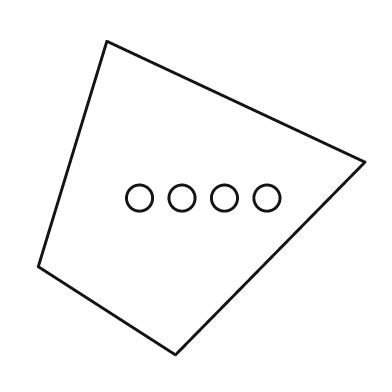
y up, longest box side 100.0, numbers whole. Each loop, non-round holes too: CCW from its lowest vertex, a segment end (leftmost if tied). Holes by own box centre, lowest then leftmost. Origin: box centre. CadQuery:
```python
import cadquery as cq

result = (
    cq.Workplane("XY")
    .moveTo(-8.0, -48.0)
    .lineTo(50.0, 11.0)
    .lineTo(-29.0, 48.0)
    .lineTo(-50.0, -21.0)
    .close()
    .moveTo(-19.0, 0.0)
    .circle(4.0)
    .moveTo(-6.0, 0.0)
    .circle(4.0)
    .moveTo(7.0, 0.0)
    .circle(4.0)
    .moveTo(20.0, 0.0)
    .circle(4.0)
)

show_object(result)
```